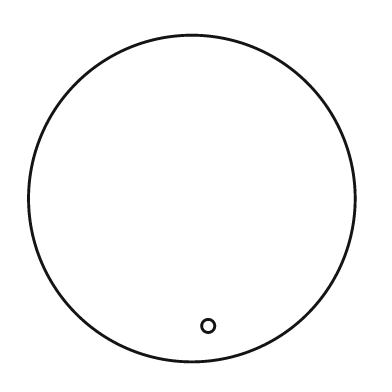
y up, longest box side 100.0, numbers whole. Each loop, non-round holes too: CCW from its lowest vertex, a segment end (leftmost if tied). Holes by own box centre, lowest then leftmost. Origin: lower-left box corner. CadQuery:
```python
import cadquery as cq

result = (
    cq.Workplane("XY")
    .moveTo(50.0, 50.0)
    .circle(50.0)
    .moveTo(55.0, 11.0)
    .circle(2.0)
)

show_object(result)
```